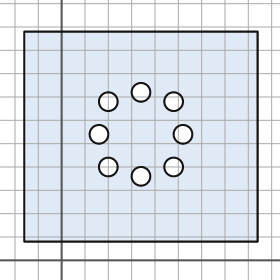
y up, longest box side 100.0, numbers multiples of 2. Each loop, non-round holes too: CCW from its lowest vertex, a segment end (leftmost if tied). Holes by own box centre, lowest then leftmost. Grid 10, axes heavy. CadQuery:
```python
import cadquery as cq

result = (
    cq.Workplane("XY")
    .moveTo(-16.0, 8.0)
    .lineTo(84.0, 8.0)
    .lineTo(84.0, 98.0)
    .lineTo(-16.0, 98.0)
    .close()
    .moveTo(34.0, 36.0)
    .circle(4.0)
    .moveTo(20.0, 40.0)
    .circle(4.0)
    .moveTo(48.0, 40.0)
    .circle(4.0)
    .moveTo(16.0, 54.0)
    .circle(4.0)
    .moveTo(52.0, 54.0)
    .circle(4.0)
    .moveTo(20.0, 68.0)
    .circle(4.0)
    .moveTo(48.0, 68.0)
    .circle(4.0)
    .moveTo(34.0, 72.0)
    .circle(4.0)
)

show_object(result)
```